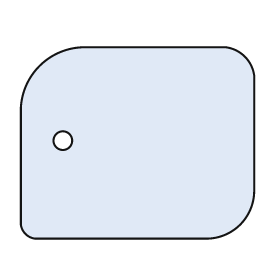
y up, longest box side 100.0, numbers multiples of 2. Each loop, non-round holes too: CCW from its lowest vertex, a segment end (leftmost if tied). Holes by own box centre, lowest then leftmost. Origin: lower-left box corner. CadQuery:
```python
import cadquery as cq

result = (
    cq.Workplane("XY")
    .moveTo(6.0, 0.0)
    .lineTo(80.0, 0.0)
    .threePointArc((94.0, 6.0), (100.0, 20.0))
    .lineTo(100.0, 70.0)
    .threePointArc((96.0, 78.0), (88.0, 82.0))
    .lineTo(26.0, 82.0)
    .threePointArc((8.0, 74.0), (0.0, 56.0))
    .lineTo(0.0, 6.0)
    .threePointArc((2.0, 2.0), (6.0, 0.0))
    .close()
    .moveTo(18.0, 42.0)
    .circle(4.0)
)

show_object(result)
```